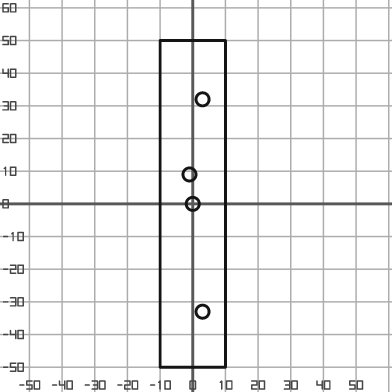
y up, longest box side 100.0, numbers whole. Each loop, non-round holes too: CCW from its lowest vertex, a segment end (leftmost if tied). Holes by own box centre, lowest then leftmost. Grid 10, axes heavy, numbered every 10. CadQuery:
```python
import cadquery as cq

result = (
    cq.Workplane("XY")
    .moveTo(-10.0, -50.0)
    .lineTo(10.0, -50.0)
    .lineTo(10.0, 50.0)
    .lineTo(-10.0, 50.0)
    .close()
    .moveTo(3.0, -33.0)
    .circle(2.0)
    .moveTo(0.0, 0.0)
    .circle(2.0)
    .moveTo(-1.0, 9.0)
    .circle(2.0)
    .moveTo(3.0, 32.0)
    .circle(2.0)
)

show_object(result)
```